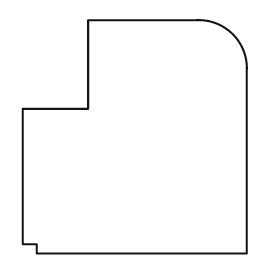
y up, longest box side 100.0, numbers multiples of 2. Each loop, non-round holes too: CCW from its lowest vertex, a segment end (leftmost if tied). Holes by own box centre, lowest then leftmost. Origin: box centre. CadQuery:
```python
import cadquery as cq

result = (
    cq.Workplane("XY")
    .moveTo(-42.0, -50.0)
    .lineTo(48.0, -50.0)
    .lineTo(48.0, 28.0)
    .threePointArc((42.0, 44.0), (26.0, 50.0))
    .lineTo(-20.0, 50.0)
    .lineTo(-20.0, 12.0)
    .lineTo(-48.0, 12.0)
    .lineTo(-48.0, -46.0)
    .lineTo(-42.0, -46.0)
    .close()
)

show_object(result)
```